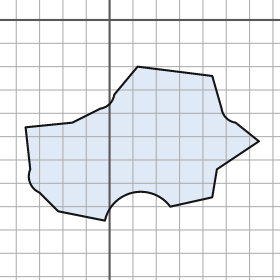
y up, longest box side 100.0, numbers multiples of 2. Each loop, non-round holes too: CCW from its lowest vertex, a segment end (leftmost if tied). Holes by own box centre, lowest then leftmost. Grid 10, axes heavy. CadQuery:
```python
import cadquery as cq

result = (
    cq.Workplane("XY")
    .moveTo(-2.0, -86.0)
    .threePointArc((10.0, -74.0), (26.0, -80.0))
    .lineTo(44.0, -76.0)
    .lineTo(46.0, -64.0)
    .lineTo(64.0, -52.0)
    .lineTo(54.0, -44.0)
    .threePointArc((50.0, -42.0), (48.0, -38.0))
    .lineTo(44.0, -24.0)
    .lineTo(12.0, -20.0)
    .lineTo(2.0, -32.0)
    .threePointArc((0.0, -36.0), (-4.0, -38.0))
    .lineTo(-16.0, -44.0)
    .lineTo(-36.0, -46.0)
    .lineTo(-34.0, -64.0)
    .threePointArc((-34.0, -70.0), (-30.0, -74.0))
    .lineTo(-22.0, -82.0)
    .close()
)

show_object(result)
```